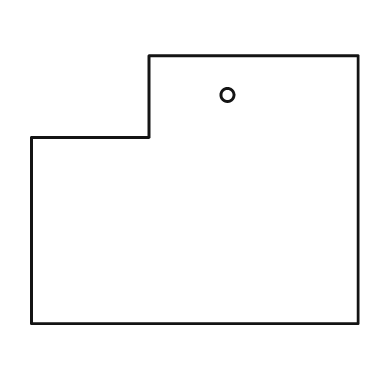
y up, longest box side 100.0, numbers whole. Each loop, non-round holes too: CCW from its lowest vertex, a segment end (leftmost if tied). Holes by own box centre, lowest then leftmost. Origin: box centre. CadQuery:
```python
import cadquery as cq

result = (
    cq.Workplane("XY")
    .moveTo(-50.0, -41.0)
    .lineTo(50.0, -41.0)
    .lineTo(50.0, 41.0)
    .lineTo(-14.0, 41.0)
    .lineTo(-14.0, 16.0)
    .lineTo(-50.0, 16.0)
    .close()
    .moveTo(10.0, 29.0)
    .circle(2.0)
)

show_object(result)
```